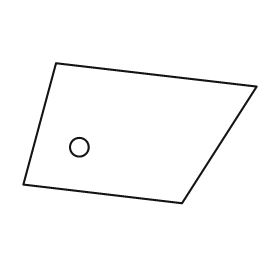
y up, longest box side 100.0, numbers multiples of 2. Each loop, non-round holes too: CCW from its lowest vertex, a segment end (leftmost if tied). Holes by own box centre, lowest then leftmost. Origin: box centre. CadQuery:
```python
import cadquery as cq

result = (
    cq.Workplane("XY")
    .moveTo(18.0, -30.0)
    .lineTo(50.0, 20.0)
    .lineTo(-36.0, 30.0)
    .lineTo(-50.0, -22.0)
    .close()
    .moveTo(-26.0, -6.0)
    .circle(4.0)
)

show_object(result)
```